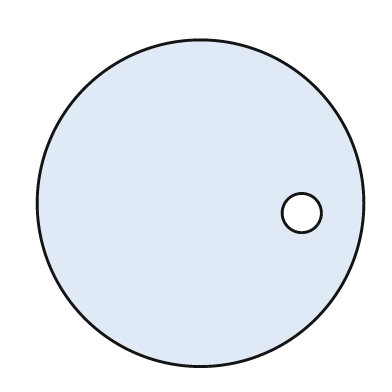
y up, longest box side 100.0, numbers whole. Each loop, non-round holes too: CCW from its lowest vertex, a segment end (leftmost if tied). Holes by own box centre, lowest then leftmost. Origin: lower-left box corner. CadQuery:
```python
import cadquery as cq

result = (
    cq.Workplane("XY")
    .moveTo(50.0, 50.0)
    .circle(50.0)
    .moveTo(81.0, 47.0)
    .circle(6.0)
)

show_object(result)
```